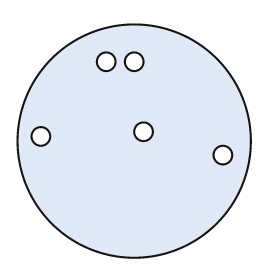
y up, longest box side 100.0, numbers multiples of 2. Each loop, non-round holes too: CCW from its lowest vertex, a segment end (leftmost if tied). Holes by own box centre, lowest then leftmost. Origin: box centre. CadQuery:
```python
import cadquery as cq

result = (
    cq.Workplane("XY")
    .moveTo(0.0, 0.0)
    .circle(50.0)
    .moveTo(38.0, -6.0)
    .circle(4.0)
    .moveTo(-40.0, 2.0)
    .circle(4.0)
    .moveTo(4.0, 4.0)
    .circle(4.0)
    .moveTo(-12.0, 34.0)
    .circle(4.0)
    .moveTo(0.0, 34.0)
    .circle(4.0)
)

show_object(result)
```